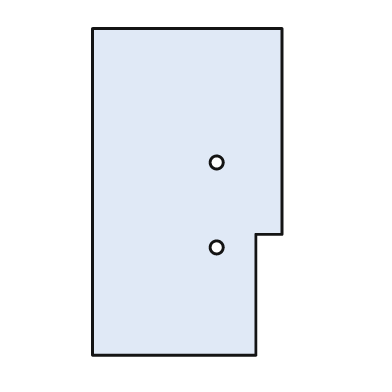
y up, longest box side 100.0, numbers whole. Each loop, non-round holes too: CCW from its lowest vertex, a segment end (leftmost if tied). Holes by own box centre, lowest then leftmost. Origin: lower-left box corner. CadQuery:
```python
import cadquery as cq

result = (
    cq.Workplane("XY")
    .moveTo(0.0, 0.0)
    .lineTo(50.0, 0.0)
    .lineTo(50.0, 37.0)
    .lineTo(58.0, 37.0)
    .lineTo(58.0, 100.0)
    .lineTo(0.0, 100.0)
    .close()
    .moveTo(38.0, 33.0)
    .circle(2.0)
    .moveTo(38.0, 59.0)
    .circle(2.0)
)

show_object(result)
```